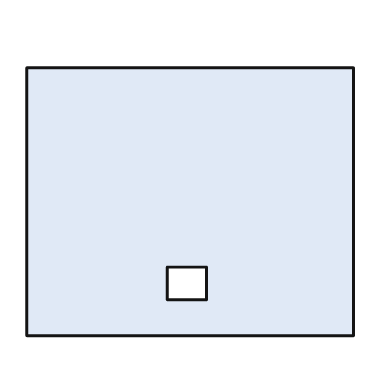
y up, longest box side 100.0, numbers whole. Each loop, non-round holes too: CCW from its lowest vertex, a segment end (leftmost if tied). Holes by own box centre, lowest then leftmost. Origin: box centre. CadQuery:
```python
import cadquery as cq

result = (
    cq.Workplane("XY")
    .moveTo(-50.0, -41.0)
    .lineTo(50.0, -41.0)
    .lineTo(50.0, 41.0)
    .lineTo(-50.0, 41.0)
    .close()
    .moveTo(-7.0, -30.0)
    .lineTo(5.0, -30.0)
    .lineTo(5.0, -20.0)
    .lineTo(-7.0, -20.0)
    .close()
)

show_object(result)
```